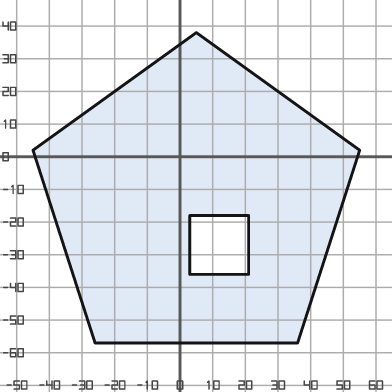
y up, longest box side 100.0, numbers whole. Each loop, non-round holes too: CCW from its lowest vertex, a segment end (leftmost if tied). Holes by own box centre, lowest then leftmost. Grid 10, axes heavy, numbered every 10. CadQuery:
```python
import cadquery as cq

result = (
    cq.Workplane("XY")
    .moveTo(-26.0, -57.0)
    .lineTo(36.0, -57.0)
    .lineTo(55.0, 2.0)
    .lineTo(5.0, 38.0)
    .lineTo(-45.0, 2.0)
    .close()
    .moveTo(3.0, -36.0)
    .lineTo(21.0, -36.0)
    .lineTo(21.0, -18.0)
    .lineTo(3.0, -18.0)
    .close()
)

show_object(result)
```